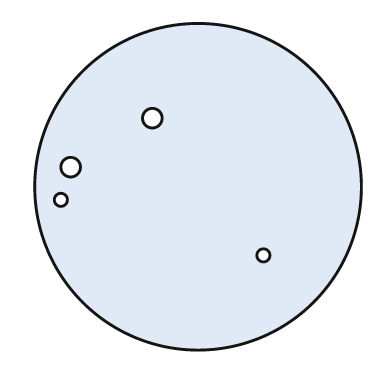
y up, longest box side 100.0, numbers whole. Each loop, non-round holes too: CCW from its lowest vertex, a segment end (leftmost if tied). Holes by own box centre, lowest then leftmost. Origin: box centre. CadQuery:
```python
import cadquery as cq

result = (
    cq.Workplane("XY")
    .moveTo(0.0, 0.0)
    .circle(50.0)
    .moveTo(20.0, -21.0)
    .circle(2.0)
    .moveTo(-42.0, -4.0)
    .circle(2.0)
    .moveTo(-39.0, 6.0)
    .circle(3.0)
    .moveTo(-14.0, 21.0)
    .circle(3.0)
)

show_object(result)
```